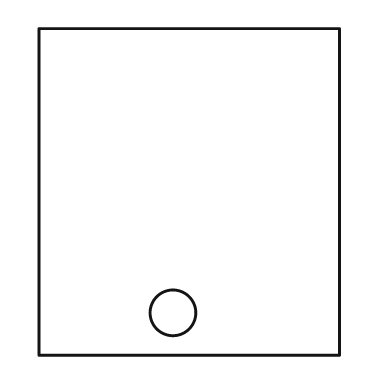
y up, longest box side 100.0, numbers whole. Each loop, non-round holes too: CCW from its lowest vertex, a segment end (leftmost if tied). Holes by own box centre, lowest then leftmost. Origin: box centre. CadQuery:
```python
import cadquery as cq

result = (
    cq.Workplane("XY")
    .moveTo(-46.0, -50.0)
    .lineTo(46.0, -50.0)
    .lineTo(46.0, 50.0)
    .lineTo(-46.0, 50.0)
    .close()
    .moveTo(-5.0, -37.0)
    .circle(7.0)
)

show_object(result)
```